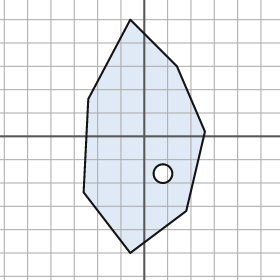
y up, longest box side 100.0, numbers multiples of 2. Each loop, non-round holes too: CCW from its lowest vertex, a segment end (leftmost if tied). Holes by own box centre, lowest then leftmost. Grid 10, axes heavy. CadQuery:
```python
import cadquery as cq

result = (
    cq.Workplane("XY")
    .moveTo(-6.0, -50.0)
    .lineTo(18.0, -32.0)
    .lineTo(26.0, 2.0)
    .lineTo(14.0, 30.0)
    .lineTo(-6.0, 50.0)
    .lineTo(-24.0, 16.0)
    .lineTo(-26.0, -24.0)
    .close()
    .moveTo(8.0, -16.0)
    .circle(4.0)
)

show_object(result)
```